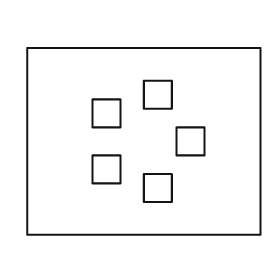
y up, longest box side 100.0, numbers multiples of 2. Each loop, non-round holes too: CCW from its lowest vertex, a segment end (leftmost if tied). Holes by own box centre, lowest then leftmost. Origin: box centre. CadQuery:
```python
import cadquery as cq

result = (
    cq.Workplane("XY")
    .moveTo(-50.0, -40.0)
    .lineTo(50.0, -40.0)
    .lineTo(50.0, 40.0)
    .lineTo(-50.0, 40.0)
    .close()
    .moveTo(0.0, -26.0)
    .lineTo(12.0, -26.0)
    .lineTo(12.0, -14.0)
    .lineTo(0.0, -14.0)
    .close()
    .moveTo(-22.0, -18.0)
    .lineTo(-10.0, -18.0)
    .lineTo(-10.0, -6.0)
    .lineTo(-22.0, -6.0)
    .close()
    .moveTo(14.0, -6.0)
    .lineTo(26.0, -6.0)
    .lineTo(26.0, 6.0)
    .lineTo(14.0, 6.0)
    .close()
    .moveTo(-22.0, 6.0)
    .lineTo(-10.0, 6.0)
    .lineTo(-10.0, 18.0)
    .lineTo(-22.0, 18.0)
    .close()
    .moveTo(0.0, 14.0)
    .lineTo(12.0, 14.0)
    .lineTo(12.0, 26.0)
    .lineTo(0.0, 26.0)
    .close()
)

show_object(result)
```